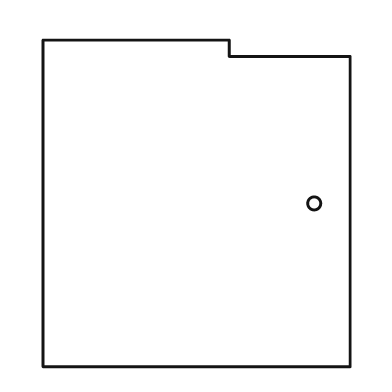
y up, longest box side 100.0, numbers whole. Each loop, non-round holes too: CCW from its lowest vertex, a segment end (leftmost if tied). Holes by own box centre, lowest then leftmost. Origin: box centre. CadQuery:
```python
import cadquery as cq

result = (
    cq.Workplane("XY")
    .moveTo(-47.0, -50.0)
    .lineTo(47.0, -50.0)
    .lineTo(47.0, 45.0)
    .lineTo(10.0, 45.0)
    .lineTo(10.0, 50.0)
    .lineTo(-47.0, 50.0)
    .close()
    .moveTo(36.0, 0.0)
    .circle(2.0)
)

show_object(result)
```